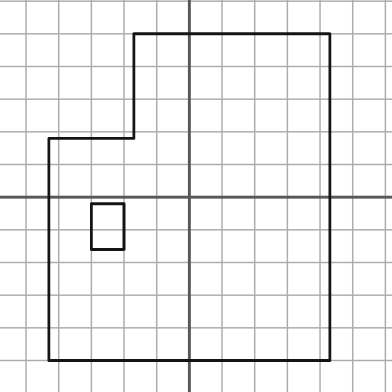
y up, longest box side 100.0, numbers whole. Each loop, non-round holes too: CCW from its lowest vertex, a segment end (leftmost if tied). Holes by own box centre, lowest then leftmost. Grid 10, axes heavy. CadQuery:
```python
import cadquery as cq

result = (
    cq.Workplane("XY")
    .moveTo(-43.0, -50.0)
    .lineTo(43.0, -50.0)
    .lineTo(43.0, 50.0)
    .lineTo(-17.0, 50.0)
    .lineTo(-17.0, 18.0)
    .lineTo(-43.0, 18.0)
    .close()
    .moveTo(-30.0, -16.0)
    .lineTo(-20.0, -16.0)
    .lineTo(-20.0, -2.0)
    .lineTo(-30.0, -2.0)
    .close()
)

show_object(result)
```